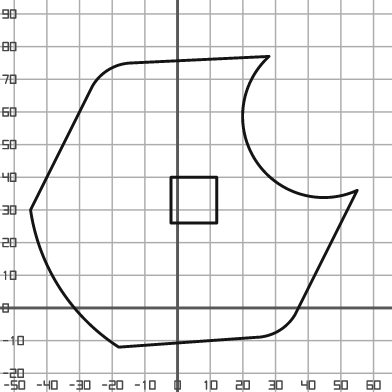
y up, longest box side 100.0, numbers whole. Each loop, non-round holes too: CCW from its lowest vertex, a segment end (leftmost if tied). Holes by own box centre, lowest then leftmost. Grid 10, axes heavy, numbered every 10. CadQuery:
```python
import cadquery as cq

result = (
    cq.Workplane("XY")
    .moveTo(-18.0, -12.0)
    .lineTo(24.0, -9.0)
    .threePointArc((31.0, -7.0), (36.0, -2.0))
    .lineTo(55.0, 36.0)
    .threePointArc((24.0, 45.0), (28.0, 77.0))
    .lineTo(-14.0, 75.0)
    .threePointArc((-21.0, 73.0), (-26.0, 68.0))
    .lineTo(-45.0, 30.0)
    .threePointArc((-36.0, 6.0), (-18.0, -12.0))
    .close()
    .moveTo(-2.0, 26.0)
    .lineTo(12.0, 26.0)
    .lineTo(12.0, 40.0)
    .lineTo(-2.0, 40.0)
    .close()
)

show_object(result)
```